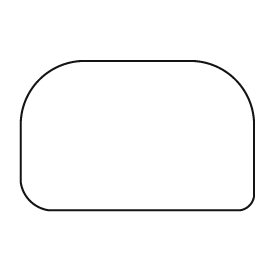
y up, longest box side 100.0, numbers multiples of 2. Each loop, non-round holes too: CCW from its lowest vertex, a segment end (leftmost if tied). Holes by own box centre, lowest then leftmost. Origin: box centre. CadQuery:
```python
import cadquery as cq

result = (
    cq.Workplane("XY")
    .moveTo(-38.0, -32.0)
    .lineTo(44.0, -32.0)
    .threePointArc((48.0, -30.0), (50.0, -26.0))
    .lineTo(50.0, 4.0)
    .threePointArc((42.0, 24.0), (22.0, 32.0))
    .lineTo(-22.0, 32.0)
    .threePointArc((-42.0, 24.0), (-50.0, 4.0))
    .lineTo(-50.0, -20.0)
    .threePointArc((-46.0, -28.0), (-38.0, -32.0))
    .close()
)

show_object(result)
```